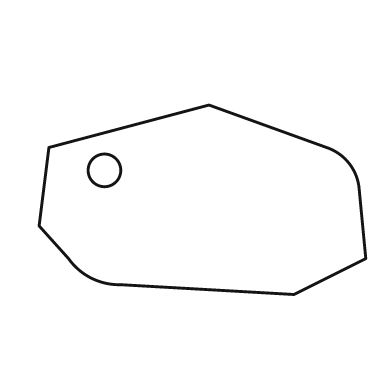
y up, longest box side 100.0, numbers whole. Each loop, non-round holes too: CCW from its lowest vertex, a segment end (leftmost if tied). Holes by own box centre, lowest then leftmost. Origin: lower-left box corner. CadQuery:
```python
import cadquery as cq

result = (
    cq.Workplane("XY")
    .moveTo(78.0, 0.0)
    .lineTo(100.0, 11.0)
    .lineTo(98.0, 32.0)
    .threePointArc((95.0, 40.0), (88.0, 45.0))
    .lineTo(52.0, 58.0)
    .lineTo(3.0, 45.0)
    .lineTo(0.0, 21.0)
    .lineTo(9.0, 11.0)
    .threePointArc((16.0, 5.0), (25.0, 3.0))
    .close()
    .moveTo(20.0, 38.0)
    .circle(5.0)
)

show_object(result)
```